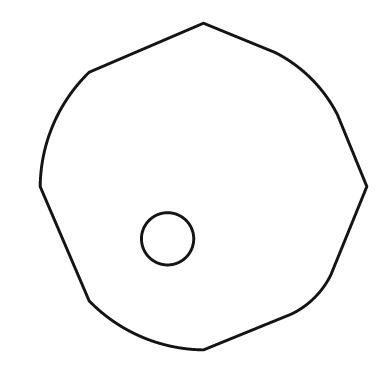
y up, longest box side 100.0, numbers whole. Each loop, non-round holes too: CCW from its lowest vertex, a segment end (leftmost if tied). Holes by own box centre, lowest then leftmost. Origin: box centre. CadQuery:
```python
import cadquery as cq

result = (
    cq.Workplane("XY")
    .moveTo(0.0, -50.0)
    .lineTo(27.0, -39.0)
    .threePointArc((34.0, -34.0), (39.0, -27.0))
    .lineTo(50.0, 0.0)
    .lineTo(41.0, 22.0)
    .threePointArc((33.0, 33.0), (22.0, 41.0))
    .lineTo(0.0, 50.0)
    .lineTo(-35.0, 35.0)
    .threePointArc((-46.0, 19.0), (-50.0, 0.0))
    .lineTo(-35.0, -35.0)
    .threePointArc((-19.0, -46.0), (0.0, -50.0))
    .close()
    .moveTo(-11.0, -16.0)
    .circle(8.0)
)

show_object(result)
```